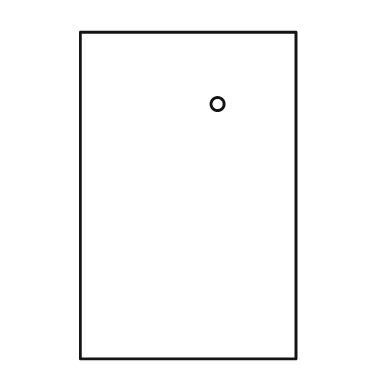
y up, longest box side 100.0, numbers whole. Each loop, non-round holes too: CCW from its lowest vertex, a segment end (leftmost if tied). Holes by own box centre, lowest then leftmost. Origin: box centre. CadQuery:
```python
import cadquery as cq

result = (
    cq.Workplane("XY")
    .moveTo(-33.0, -50.0)
    .lineTo(33.0, -50.0)
    .lineTo(33.0, 50.0)
    .lineTo(-33.0, 50.0)
    .close()
    .moveTo(9.0, 28.0)
    .circle(2.0)
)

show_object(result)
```